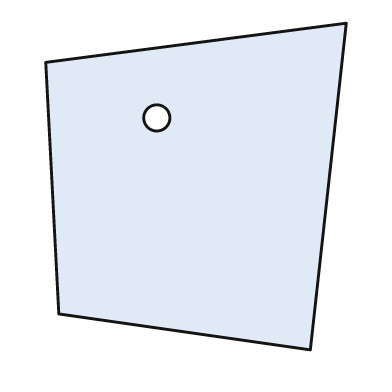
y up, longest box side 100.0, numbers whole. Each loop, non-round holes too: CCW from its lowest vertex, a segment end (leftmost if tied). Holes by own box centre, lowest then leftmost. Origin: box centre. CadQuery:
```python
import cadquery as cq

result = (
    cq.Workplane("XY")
    .moveTo(35.0, -50.0)
    .lineTo(46.0, 50.0)
    .lineTo(-46.0, 38.0)
    .lineTo(-42.0, -39.0)
    .close()
    .moveTo(-12.0, 21.0)
    .circle(4.0)
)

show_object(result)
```